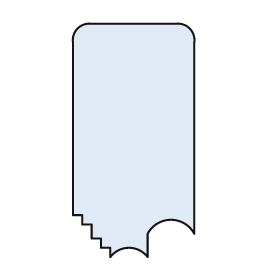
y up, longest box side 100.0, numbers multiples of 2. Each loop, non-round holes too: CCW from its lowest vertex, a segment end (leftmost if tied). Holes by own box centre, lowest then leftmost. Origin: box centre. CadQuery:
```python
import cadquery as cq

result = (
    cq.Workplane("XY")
    .moveTo(-10.0, -50.0)
    .threePointArc((-2.0, -46.0), (6.0, -50.0))
    .lineTo(6.0, -40.0)
    .threePointArc((16.0, -34.0), (26.0, -40.0))
    .lineTo(26.0, 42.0)
    .threePointArc((24.0, 48.0), (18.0, 50.0))
    .lineTo(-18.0, 50.0)
    .threePointArc((-24.0, 48.0), (-26.0, 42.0))
    .lineTo(-26.0, -32.0)
    .lineTo(-22.0, -32.0)
    .lineTo(-22.0, -36.0)
    .lineTo(-18.0, -36.0)
    .lineTo(-18.0, -42.0)
    .lineTo(-14.0, -42.0)
    .lineTo(-14.0, -46.0)
    .lineTo(-10.0, -46.0)
    .close()
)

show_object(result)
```